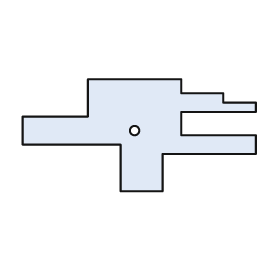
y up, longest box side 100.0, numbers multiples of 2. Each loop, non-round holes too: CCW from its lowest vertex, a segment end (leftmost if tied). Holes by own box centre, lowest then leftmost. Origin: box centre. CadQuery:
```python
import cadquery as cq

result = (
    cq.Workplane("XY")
    .moveTo(-8.0, -24.0)
    .lineTo(10.0, -24.0)
    .lineTo(10.0, -8.0)
    .lineTo(50.0, -8.0)
    .lineTo(50.0, 0.0)
    .lineTo(18.0, 0.0)
    .lineTo(18.0, 10.0)
    .lineTo(50.0, 10.0)
    .lineTo(50.0, 14.0)
    .lineTo(36.0, 14.0)
    .lineTo(36.0, 18.0)
    .lineTo(18.0, 18.0)
    .lineTo(18.0, 24.0)
    .lineTo(-22.0, 24.0)
    .lineTo(-22.0, 8.0)
    .lineTo(-50.0, 8.0)
    .lineTo(-50.0, -4.0)
    .lineTo(-8.0, -4.0)
    .close()
    .moveTo(-2.0, 2.0)
    .circle(2.0)
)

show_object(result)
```